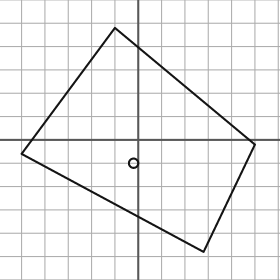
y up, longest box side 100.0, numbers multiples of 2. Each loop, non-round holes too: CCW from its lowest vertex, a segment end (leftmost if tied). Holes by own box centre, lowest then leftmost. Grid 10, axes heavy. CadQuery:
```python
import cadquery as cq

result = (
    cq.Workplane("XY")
    .moveTo(28.0, -48.0)
    .lineTo(50.0, -2.0)
    .lineTo(-10.0, 48.0)
    .lineTo(-50.0, -6.0)
    .close()
    .moveTo(-2.0, -10.0)
    .circle(2.0)
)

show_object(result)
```